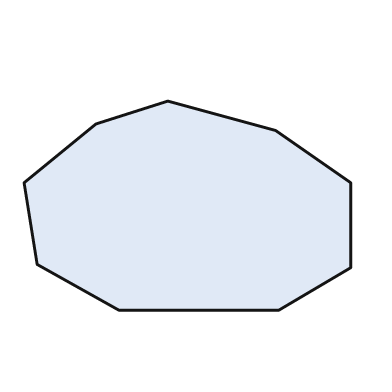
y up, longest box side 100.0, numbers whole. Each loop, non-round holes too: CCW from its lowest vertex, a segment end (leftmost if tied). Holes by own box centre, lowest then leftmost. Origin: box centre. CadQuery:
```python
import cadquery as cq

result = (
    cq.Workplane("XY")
    .moveTo(-21.0, -32.0)
    .lineTo(28.0, -32.0)
    .lineTo(50.0, -19.0)
    .lineTo(50.0, 7.0)
    .lineTo(27.0, 23.0)
    .lineTo(-6.0, 32.0)
    .lineTo(-28.0, 25.0)
    .lineTo(-50.0, 7.0)
    .lineTo(-46.0, -18.0)
    .close()
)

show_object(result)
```